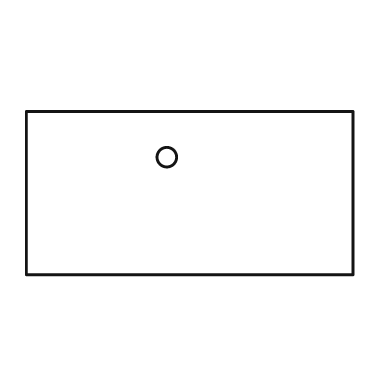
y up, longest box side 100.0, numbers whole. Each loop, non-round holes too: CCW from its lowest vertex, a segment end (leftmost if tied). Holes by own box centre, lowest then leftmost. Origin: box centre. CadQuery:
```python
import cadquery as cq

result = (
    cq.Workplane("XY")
    .moveTo(-50.0, -25.0)
    .lineTo(50.0, -25.0)
    .lineTo(50.0, 25.0)
    .lineTo(-50.0, 25.0)
    .close()
    .moveTo(-7.0, 11.0)
    .circle(3.0)
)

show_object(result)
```